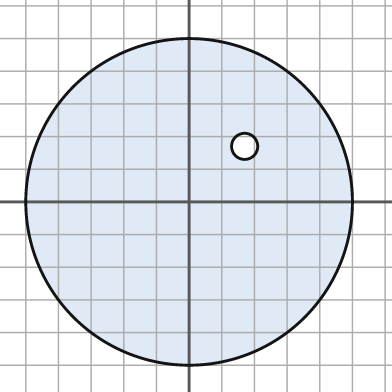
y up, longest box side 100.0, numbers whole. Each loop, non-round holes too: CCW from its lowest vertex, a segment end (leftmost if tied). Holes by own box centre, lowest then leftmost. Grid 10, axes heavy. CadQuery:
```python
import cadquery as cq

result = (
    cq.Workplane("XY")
    .moveTo(0.0, 0.0)
    .circle(50.0)
    .moveTo(17.0, 17.0)
    .circle(4.0)
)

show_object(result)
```